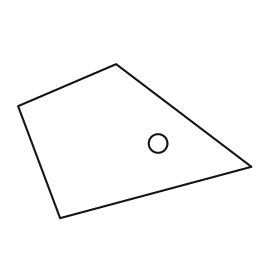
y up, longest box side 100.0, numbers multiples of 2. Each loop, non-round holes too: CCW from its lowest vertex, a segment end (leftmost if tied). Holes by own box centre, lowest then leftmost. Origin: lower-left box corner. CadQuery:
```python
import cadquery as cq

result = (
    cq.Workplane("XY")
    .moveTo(18.0, 0.0)
    .lineTo(100.0, 22.0)
    .lineTo(42.0, 66.0)
    .lineTo(0.0, 48.0)
    .close()
    .moveTo(60.0, 32.0)
    .circle(4.0)
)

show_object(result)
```